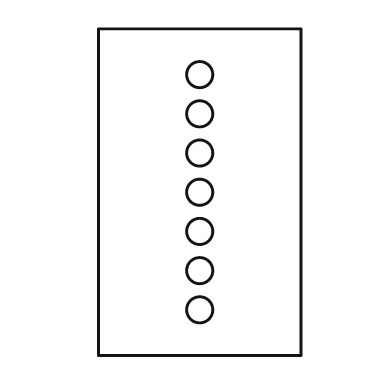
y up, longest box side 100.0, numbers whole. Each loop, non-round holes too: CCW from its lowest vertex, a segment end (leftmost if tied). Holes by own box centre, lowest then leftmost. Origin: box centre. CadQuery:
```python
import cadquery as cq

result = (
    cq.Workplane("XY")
    .moveTo(-31.0, -50.0)
    .lineTo(31.0, -50.0)
    .lineTo(31.0, 50.0)
    .lineTo(-31.0, 50.0)
    .close()
    .moveTo(0.0, -36.0)
    .circle(4.0)
    .moveTo(0.0, -24.0)
    .circle(4.0)
    .moveTo(0.0, -12.0)
    .circle(4.0)
    .moveTo(0.0, 0.0)
    .circle(4.0)
    .moveTo(0.0, 12.0)
    .circle(4.0)
    .moveTo(0.0, 24.0)
    .circle(4.0)
    .moveTo(0.0, 36.0)
    .circle(4.0)
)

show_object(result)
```